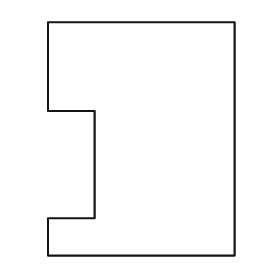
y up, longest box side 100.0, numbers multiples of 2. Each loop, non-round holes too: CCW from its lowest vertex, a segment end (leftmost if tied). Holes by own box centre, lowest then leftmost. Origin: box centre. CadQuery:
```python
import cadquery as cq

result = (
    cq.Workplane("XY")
    .moveTo(-40.0, -50.0)
    .lineTo(40.0, -50.0)
    .lineTo(40.0, 50.0)
    .lineTo(-40.0, 50.0)
    .lineTo(-40.0, 12.0)
    .lineTo(-20.0, 12.0)
    .lineTo(-20.0, -34.0)
    .lineTo(-40.0, -34.0)
    .close()
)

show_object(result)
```